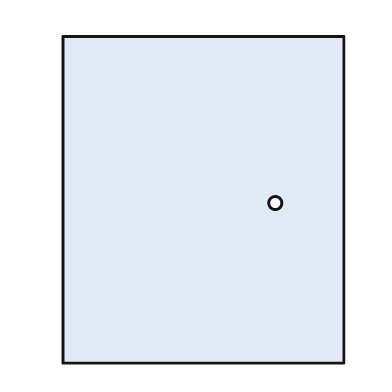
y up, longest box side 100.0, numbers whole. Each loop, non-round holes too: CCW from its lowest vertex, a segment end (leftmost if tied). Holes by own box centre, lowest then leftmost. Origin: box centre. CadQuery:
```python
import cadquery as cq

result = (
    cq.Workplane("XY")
    .moveTo(-43.0, -50.0)
    .lineTo(43.0, -50.0)
    .lineTo(43.0, 50.0)
    .lineTo(-43.0, 50.0)
    .close()
    .moveTo(22.0, -1.0)
    .circle(2.0)
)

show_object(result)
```